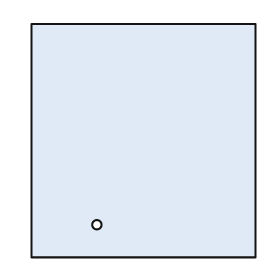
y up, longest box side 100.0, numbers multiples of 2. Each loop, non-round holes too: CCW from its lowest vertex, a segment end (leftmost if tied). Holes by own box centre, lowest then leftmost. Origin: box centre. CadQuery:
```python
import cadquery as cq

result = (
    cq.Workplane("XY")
    .moveTo(-48.0, -50.0)
    .lineTo(48.0, -50.0)
    .lineTo(48.0, 50.0)
    .lineTo(-48.0, 50.0)
    .close()
    .moveTo(-20.0, -36.0)
    .circle(2.0)
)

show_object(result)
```